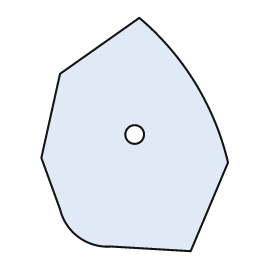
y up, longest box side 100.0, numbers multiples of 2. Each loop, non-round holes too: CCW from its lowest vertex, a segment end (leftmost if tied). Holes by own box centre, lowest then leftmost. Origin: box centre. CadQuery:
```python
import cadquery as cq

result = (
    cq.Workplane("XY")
    .moveTo(24.0, -50.0)
    .lineTo(40.0, -12.0)
    .threePointArc((26.0, 22.0), (2.0, 50.0))
    .lineTo(-32.0, 26.0)
    .lineTo(-40.0, -10.0)
    .lineTo(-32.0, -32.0)
    .threePointArc((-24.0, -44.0), (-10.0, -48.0))
    .close()
    .moveTo(0.0, 0.0)
    .circle(4.0)
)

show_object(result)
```